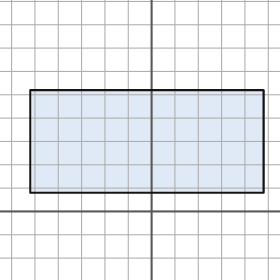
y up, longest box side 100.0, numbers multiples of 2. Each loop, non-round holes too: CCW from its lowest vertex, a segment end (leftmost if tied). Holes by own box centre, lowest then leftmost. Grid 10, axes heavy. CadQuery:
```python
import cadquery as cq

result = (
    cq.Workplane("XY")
    .moveTo(-52.0, 8.0)
    .lineTo(48.0, 8.0)
    .lineTo(48.0, 52.0)
    .lineTo(-52.0, 52.0)
    .close()
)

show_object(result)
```